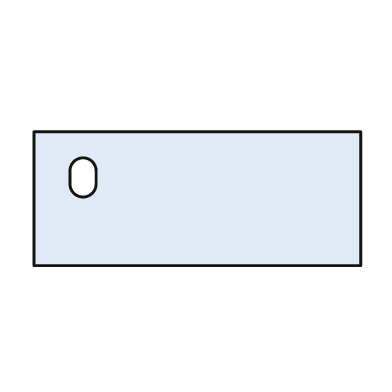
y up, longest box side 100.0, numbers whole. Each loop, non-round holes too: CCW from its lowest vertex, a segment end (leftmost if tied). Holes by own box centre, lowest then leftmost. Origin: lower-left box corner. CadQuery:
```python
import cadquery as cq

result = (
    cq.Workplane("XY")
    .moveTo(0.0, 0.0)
    .lineTo(100.0, 0.0)
    .lineTo(100.0, 41.0)
    .lineTo(0.0, 41.0)
    .close()
    .moveTo(11.0, 25.0)
    .threePointArc((15.0, 21.0), (19.0, 25.0))
    .lineTo(19.0, 29.0)
    .threePointArc((15.0, 33.0), (11.0, 29.0))
    .close()
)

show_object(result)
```